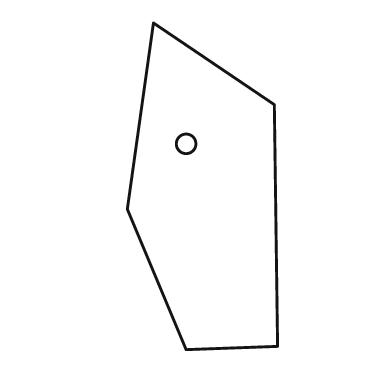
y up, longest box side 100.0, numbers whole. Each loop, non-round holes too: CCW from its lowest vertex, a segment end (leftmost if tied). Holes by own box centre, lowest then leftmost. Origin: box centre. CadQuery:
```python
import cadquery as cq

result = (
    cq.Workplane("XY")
    .moveTo(-5.0, -50.0)
    .lineTo(23.0, -49.0)
    .lineTo(22.0, 25.0)
    .lineTo(-15.0, 50.0)
    .lineTo(-23.0, -7.0)
    .close()
    .moveTo(-5.0, 13.0)
    .circle(3.0)
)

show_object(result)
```